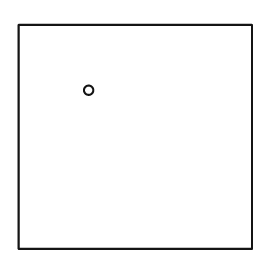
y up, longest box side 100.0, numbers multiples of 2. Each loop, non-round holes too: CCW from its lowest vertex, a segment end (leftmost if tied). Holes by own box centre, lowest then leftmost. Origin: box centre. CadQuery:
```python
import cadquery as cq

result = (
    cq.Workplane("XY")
    .moveTo(-50.0, -48.0)
    .lineTo(50.0, -48.0)
    .lineTo(50.0, 48.0)
    .lineTo(-50.0, 48.0)
    .close()
    .moveTo(-20.0, 20.0)
    .circle(2.0)
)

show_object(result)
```